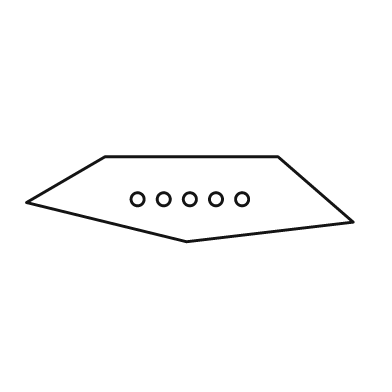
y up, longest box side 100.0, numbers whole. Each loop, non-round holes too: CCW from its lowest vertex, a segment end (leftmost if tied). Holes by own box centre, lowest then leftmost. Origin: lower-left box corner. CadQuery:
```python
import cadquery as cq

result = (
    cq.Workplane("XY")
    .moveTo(49.0, 0.0)
    .lineTo(100.0, 6.0)
    .lineTo(77.0, 26.0)
    .lineTo(24.0, 26.0)
    .lineTo(0.0, 12.0)
    .close()
    .moveTo(34.0, 13.0)
    .circle(2.0)
    .moveTo(42.0, 13.0)
    .circle(2.0)
    .moveTo(50.0, 13.0)
    .circle(2.0)
    .moveTo(58.0, 13.0)
    .circle(2.0)
    .moveTo(66.0, 13.0)
    .circle(2.0)
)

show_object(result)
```